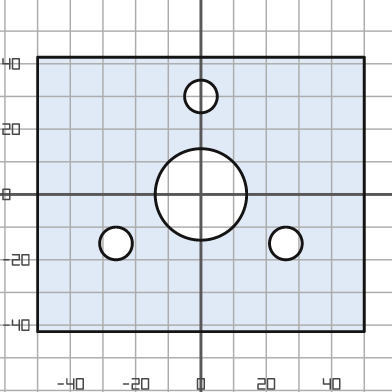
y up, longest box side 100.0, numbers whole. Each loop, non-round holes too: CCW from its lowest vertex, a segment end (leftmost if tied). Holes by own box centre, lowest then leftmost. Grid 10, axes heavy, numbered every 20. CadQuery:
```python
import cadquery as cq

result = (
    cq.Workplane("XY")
    .moveTo(-50.0, -42.0)
    .lineTo(50.0, -42.0)
    .lineTo(50.0, 42.0)
    .lineTo(-50.0, 42.0)
    .close()
    .moveTo(-26.0, -15.0)
    .circle(5.0)
    .moveTo(26.0, -15.0)
    .circle(5.0)
    .moveTo(0.0, 0.0)
    .circle(14.0)
    .moveTo(0.0, 30.0)
    .circle(5.0)
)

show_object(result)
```